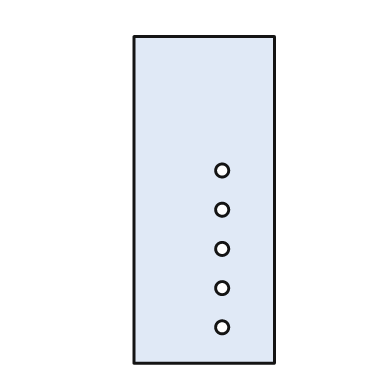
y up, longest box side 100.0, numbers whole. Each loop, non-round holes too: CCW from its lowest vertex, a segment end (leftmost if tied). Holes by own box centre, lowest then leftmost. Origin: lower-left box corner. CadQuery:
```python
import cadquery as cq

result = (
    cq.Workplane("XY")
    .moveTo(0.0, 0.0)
    .lineTo(43.0, 0.0)
    .lineTo(43.0, 100.0)
    .lineTo(0.0, 100.0)
    .close()
    .moveTo(27.0, 11.0)
    .circle(2.0)
    .moveTo(27.0, 23.0)
    .circle(2.0)
    .moveTo(27.0, 35.0)
    .circle(2.0)
    .moveTo(27.0, 47.0)
    .circle(2.0)
    .moveTo(27.0, 59.0)
    .circle(2.0)
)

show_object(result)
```